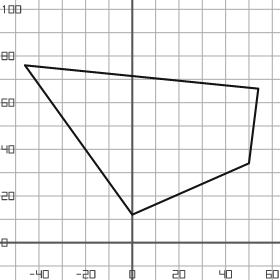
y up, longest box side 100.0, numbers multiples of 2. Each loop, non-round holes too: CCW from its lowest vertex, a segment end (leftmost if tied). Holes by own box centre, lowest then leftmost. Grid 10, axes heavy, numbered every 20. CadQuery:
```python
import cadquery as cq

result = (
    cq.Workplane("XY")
    .moveTo(0.0, 12.0)
    .lineTo(50.0, 34.0)
    .lineTo(54.0, 66.0)
    .lineTo(-46.0, 76.0)
    .close()
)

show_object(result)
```